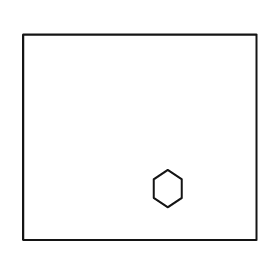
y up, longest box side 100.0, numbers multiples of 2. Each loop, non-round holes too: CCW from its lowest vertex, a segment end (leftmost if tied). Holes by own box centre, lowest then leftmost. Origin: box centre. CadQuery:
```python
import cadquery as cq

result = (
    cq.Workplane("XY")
    .moveTo(-50.0, -44.0)
    .lineTo(50.0, -44.0)
    .lineTo(50.0, 44.0)
    .lineTo(-50.0, 44.0)
    .close()
    .moveTo(12.0, -30.0)
    .lineTo(18.0, -26.0)
    .lineTo(18.0, -18.0)
    .lineTo(12.0, -14.0)
    .lineTo(6.0, -18.0)
    .lineTo(6.0, -26.0)
    .close()
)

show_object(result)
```